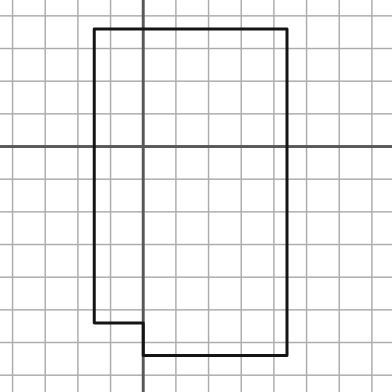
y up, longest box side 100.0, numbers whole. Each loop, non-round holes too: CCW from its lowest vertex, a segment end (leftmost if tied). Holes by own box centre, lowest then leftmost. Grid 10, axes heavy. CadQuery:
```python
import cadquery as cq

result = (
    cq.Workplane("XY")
    .moveTo(0.0, -64.0)
    .lineTo(44.0, -64.0)
    .lineTo(44.0, 36.0)
    .lineTo(-15.0, 36.0)
    .lineTo(-15.0, -54.0)
    .lineTo(0.0, -54.0)
    .close()
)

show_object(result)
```